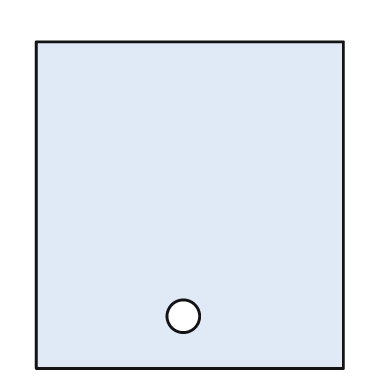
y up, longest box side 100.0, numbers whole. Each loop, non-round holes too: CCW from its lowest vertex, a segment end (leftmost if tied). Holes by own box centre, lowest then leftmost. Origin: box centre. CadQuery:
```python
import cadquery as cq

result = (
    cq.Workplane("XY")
    .moveTo(-47.0, -50.0)
    .lineTo(47.0, -50.0)
    .lineTo(47.0, 50.0)
    .lineTo(-47.0, 50.0)
    .close()
    .moveTo(-2.0, -34.0)
    .circle(5.0)
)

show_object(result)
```